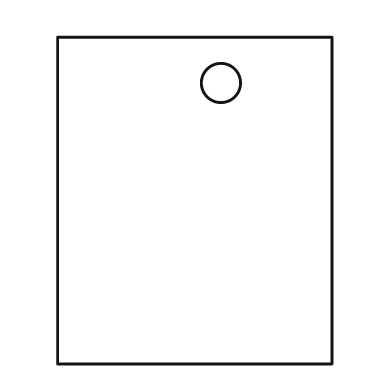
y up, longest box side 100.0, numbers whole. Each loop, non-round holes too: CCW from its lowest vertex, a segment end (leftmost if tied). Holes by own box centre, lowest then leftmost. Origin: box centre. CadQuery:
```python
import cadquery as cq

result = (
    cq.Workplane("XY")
    .moveTo(-42.0, -50.0)
    .lineTo(42.0, -50.0)
    .lineTo(42.0, 50.0)
    .lineTo(-42.0, 50.0)
    .close()
    .moveTo(8.0, 36.0)
    .circle(6.0)
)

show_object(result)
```